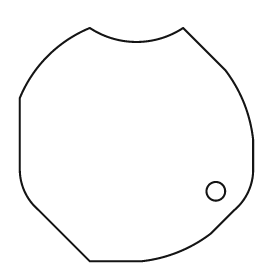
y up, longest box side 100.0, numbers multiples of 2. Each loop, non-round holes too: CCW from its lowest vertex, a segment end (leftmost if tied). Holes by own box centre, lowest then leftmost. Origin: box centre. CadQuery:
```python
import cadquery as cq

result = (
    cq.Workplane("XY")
    .moveTo(-20.0, -50.0)
    .lineTo(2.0, -50.0)
    .threePointArc((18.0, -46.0), (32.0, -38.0))
    .lineTo(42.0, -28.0)
    .threePointArc((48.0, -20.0), (50.0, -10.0))
    .lineTo(50.0, 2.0)
    .threePointArc((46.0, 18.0), (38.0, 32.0))
    .lineTo(20.0, 50.0)
    .threePointArc((0.0, 44.0), (-20.0, 50.0))
    .threePointArc((-38.0, 38.0), (-50.0, 20.0))
    .lineTo(-50.0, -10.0)
    .threePointArc((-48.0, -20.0), (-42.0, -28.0))
    .close()
    .moveTo(34.0, -20.0)
    .circle(4.0)
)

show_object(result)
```